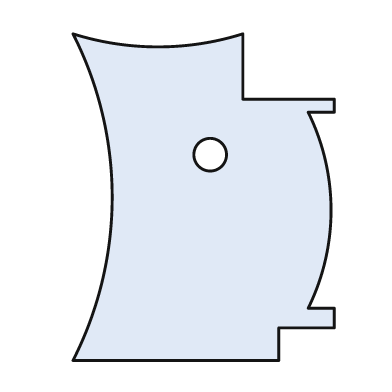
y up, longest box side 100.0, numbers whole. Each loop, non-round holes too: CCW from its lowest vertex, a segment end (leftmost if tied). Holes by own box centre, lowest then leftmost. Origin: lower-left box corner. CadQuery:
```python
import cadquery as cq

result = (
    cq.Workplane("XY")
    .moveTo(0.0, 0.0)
    .lineTo(63.0, 0.0)
    .lineTo(63.0, 10.0)
    .lineTo(80.0, 10.0)
    .lineTo(80.0, 16.0)
    .lineTo(72.0, 16.0)
    .threePointArc((79.0, 46.0), (72.0, 76.0))
    .lineTo(80.0, 76.0)
    .lineTo(80.0, 80.0)
    .lineTo(52.0, 80.0)
    .lineTo(52.0, 100.0)
    .threePointArc((26.0, 96.0), (0.0, 100.0))
    .threePointArc((12.0, 50.0), (0.0, 0.0))
    .close()
    .moveTo(42.0, 63.0)
    .circle(5.0)
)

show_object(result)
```